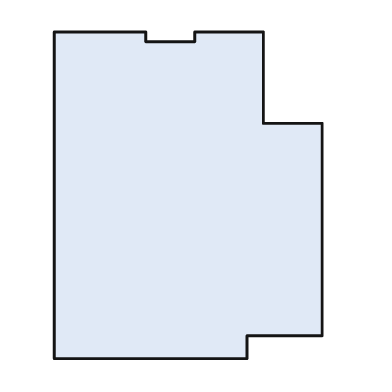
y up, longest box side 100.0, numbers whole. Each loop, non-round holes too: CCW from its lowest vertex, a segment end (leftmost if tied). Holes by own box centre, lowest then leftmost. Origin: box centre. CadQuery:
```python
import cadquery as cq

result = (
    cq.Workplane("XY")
    .moveTo(-41.0, -50.0)
    .lineTo(18.0, -50.0)
    .lineTo(18.0, -43.0)
    .lineTo(41.0, -43.0)
    .lineTo(41.0, 22.0)
    .lineTo(23.0, 22.0)
    .lineTo(23.0, 50.0)
    .lineTo(2.0, 50.0)
    .lineTo(2.0, 47.0)
    .lineTo(-13.0, 47.0)
    .lineTo(-13.0, 50.0)
    .lineTo(-41.0, 50.0)
    .close()
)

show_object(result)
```